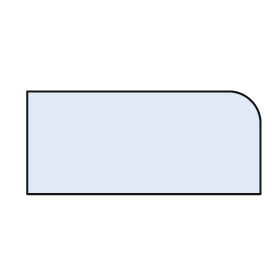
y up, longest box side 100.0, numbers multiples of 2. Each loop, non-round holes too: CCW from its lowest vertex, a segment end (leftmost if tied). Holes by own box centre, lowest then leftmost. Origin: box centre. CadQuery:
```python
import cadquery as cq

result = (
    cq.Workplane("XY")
    .moveTo(-50.0, -22.0)
    .lineTo(50.0, -22.0)
    .lineTo(50.0, 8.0)
    .threePointArc((46.0, 18.0), (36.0, 22.0))
    .lineTo(-50.0, 22.0)
    .close()
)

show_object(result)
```